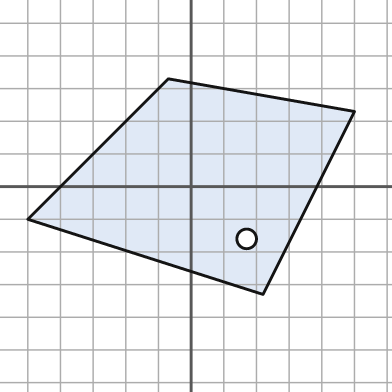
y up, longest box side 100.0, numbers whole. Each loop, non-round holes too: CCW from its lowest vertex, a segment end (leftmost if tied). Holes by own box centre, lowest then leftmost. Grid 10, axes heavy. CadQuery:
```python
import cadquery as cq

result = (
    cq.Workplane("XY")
    .moveTo(22.0, -33.0)
    .lineTo(50.0, 23.0)
    .lineTo(-7.0, 33.0)
    .lineTo(-50.0, -10.0)
    .close()
    .moveTo(17.0, -16.0)
    .circle(3.0)
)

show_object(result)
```